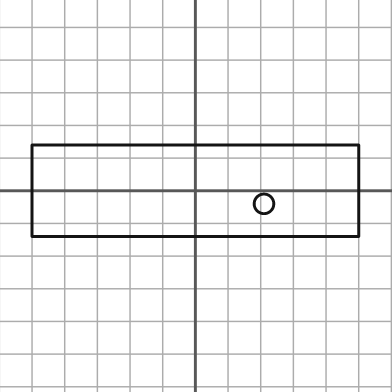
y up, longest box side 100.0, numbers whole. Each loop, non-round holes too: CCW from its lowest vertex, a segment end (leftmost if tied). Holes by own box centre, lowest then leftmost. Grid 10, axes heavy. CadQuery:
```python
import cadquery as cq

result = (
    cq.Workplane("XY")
    .moveTo(-50.0, -14.0)
    .lineTo(50.0, -14.0)
    .lineTo(50.0, 14.0)
    .lineTo(-50.0, 14.0)
    .close()
    .moveTo(21.0, -4.0)
    .circle(3.0)
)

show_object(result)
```